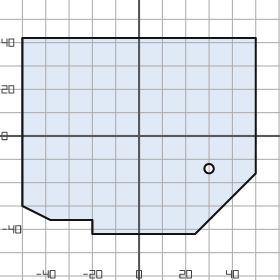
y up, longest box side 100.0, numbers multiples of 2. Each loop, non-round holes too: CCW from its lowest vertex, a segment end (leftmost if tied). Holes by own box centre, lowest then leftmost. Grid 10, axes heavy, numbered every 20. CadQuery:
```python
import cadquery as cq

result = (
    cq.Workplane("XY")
    .moveTo(-20.0, -42.0)
    .lineTo(24.0, -42.0)
    .lineTo(50.0, -16.0)
    .lineTo(50.0, 42.0)
    .lineTo(-50.0, 42.0)
    .lineTo(-50.0, -30.0)
    .lineTo(-38.0, -36.0)
    .lineTo(-20.0, -36.0)
    .close()
    .moveTo(30.0, -14.0)
    .circle(2.0)
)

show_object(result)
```